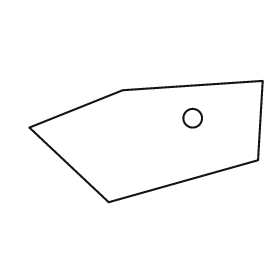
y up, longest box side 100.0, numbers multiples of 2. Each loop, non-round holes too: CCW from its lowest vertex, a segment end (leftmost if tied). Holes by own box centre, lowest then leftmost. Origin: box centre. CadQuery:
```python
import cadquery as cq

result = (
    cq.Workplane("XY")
    .moveTo(-16.0, -26.0)
    .lineTo(48.0, -8.0)
    .lineTo(50.0, 26.0)
    .lineTo(-10.0, 22.0)
    .lineTo(-50.0, 6.0)
    .close()
    .moveTo(20.0, 10.0)
    .circle(4.0)
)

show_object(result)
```